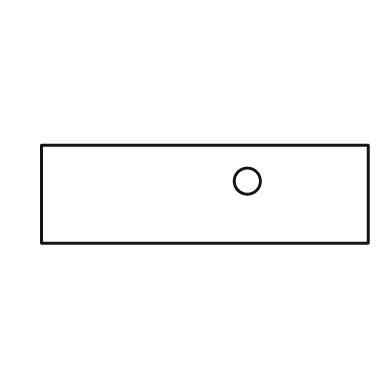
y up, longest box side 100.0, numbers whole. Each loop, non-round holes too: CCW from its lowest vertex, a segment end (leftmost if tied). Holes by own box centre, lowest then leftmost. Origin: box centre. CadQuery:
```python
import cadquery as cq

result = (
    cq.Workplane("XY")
    .moveTo(-50.0, -15.0)
    .lineTo(50.0, -15.0)
    .lineTo(50.0, 15.0)
    .lineTo(-50.0, 15.0)
    .close()
    .moveTo(13.0, 4.0)
    .circle(4.0)
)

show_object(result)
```